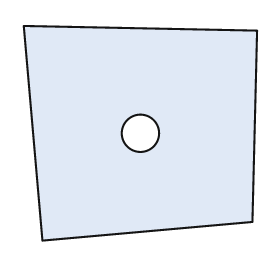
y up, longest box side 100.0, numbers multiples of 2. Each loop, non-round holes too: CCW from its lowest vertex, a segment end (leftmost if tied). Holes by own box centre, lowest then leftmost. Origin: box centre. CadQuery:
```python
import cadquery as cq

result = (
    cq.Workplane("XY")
    .moveTo(-42.0, -46.0)
    .lineTo(48.0, -38.0)
    .lineTo(50.0, 44.0)
    .lineTo(-50.0, 46.0)
    .close()
    .moveTo(0.0, 0.0)
    .circle(8.0)
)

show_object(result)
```